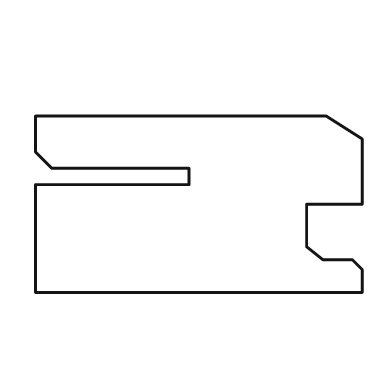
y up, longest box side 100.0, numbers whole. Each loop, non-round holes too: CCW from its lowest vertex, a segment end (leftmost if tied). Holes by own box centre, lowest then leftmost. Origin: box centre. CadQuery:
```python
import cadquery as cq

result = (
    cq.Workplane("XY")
    .moveTo(-50.0, -27.0)
    .lineTo(50.0, -27.0)
    .lineTo(50.0, -20.0)
    .lineTo(47.0, -17.0)
    .lineTo(38.0, -17.0)
    .lineTo(33.0, -13.0)
    .lineTo(33.0, 0.0)
    .lineTo(50.0, 0.0)
    .lineTo(50.0, 20.0)
    .lineTo(39.0, 27.0)
    .lineTo(-50.0, 27.0)
    .lineTo(-50.0, 16.0)
    .lineTo(-45.0, 11.0)
    .lineTo(-3.0, 11.0)
    .lineTo(-3.0, 6.0)
    .lineTo(-50.0, 6.0)
    .close()
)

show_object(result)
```